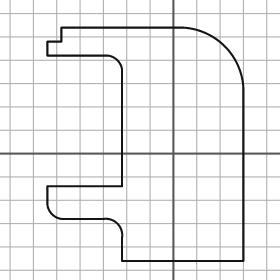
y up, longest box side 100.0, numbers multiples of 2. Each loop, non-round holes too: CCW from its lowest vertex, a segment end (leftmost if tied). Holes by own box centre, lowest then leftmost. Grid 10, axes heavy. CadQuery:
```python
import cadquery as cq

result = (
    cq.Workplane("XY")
    .moveTo(-22.0, -46.0)
    .lineTo(30.0, -46.0)
    .lineTo(30.0, 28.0)
    .threePointArc((22.0, 46.0), (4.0, 54.0))
    .lineTo(-48.0, 54.0)
    .lineTo(-48.0, 48.0)
    .lineTo(-54.0, 48.0)
    .lineTo(-54.0, 42.0)
    .lineTo(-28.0, 42.0)
    .threePointArc((-24.0, 40.0), (-22.0, 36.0))
    .lineTo(-22.0, -14.0)
    .lineTo(-54.0, -14.0)
    .lineTo(-54.0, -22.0)
    .threePointArc((-52.0, -26.0), (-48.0, -28.0))
    .lineTo(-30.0, -28.0)
    .threePointArc((-24.0, -30.0), (-22.0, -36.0))
    .close()
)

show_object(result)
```